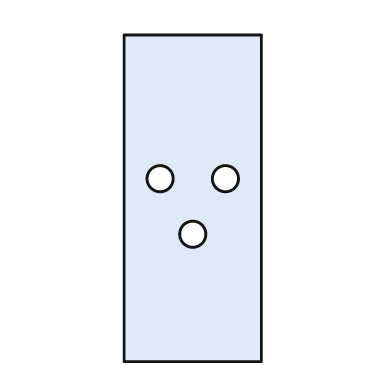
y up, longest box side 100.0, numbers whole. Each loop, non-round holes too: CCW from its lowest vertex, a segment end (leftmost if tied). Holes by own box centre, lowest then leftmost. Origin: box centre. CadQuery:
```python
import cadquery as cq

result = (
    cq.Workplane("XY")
    .moveTo(-21.0, -50.0)
    .lineTo(21.0, -50.0)
    .lineTo(21.0, 50.0)
    .lineTo(-21.0, 50.0)
    .close()
    .moveTo(0.0, -11.0)
    .circle(4.0)
    .moveTo(-10.0, 6.0)
    .circle(4.0)
    .moveTo(10.0, 6.0)
    .circle(4.0)
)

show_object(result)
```